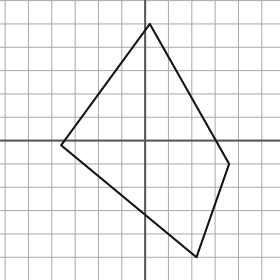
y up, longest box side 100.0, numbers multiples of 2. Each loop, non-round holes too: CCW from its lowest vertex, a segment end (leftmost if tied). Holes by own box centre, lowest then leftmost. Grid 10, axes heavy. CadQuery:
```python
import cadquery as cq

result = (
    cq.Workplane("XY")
    .moveTo(22.0, -50.0)
    .lineTo(36.0, -10.0)
    .lineTo(2.0, 50.0)
    .lineTo(-36.0, -2.0)
    .close()
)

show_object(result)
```